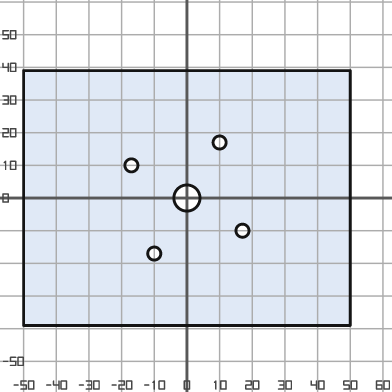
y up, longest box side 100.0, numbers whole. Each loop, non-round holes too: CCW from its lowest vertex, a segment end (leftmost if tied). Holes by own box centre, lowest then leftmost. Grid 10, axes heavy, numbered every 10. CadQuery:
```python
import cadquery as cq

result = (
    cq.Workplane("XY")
    .moveTo(-50.0, -39.0)
    .lineTo(50.0, -39.0)
    .lineTo(50.0, 39.0)
    .lineTo(-50.0, 39.0)
    .close()
    .moveTo(-10.0, -17.0)
    .circle(2.0)
    .moveTo(17.0, -10.0)
    .circle(2.0)
    .moveTo(0.0, 0.0)
    .circle(4.0)
    .moveTo(-17.0, 10.0)
    .circle(2.0)
    .moveTo(10.0, 17.0)
    .circle(2.0)
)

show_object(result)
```